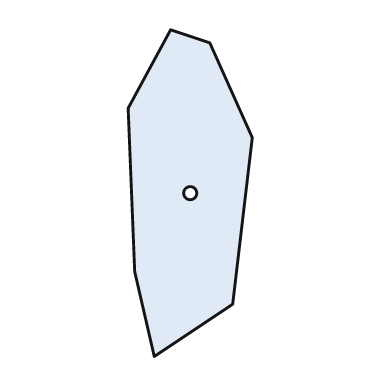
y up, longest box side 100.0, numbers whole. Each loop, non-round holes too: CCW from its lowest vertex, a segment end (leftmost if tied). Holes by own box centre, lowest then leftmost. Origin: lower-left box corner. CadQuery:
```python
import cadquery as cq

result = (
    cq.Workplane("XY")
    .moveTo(8.0, 0.0)
    .lineTo(32.0, 16.0)
    .lineTo(38.0, 67.0)
    .lineTo(25.0, 96.0)
    .lineTo(13.0, 100.0)
    .lineTo(0.0, 76.0)
    .lineTo(2.0, 26.0)
    .close()
    .moveTo(19.0, 50.0)
    .circle(2.0)
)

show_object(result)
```